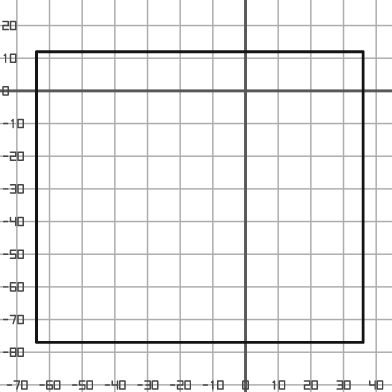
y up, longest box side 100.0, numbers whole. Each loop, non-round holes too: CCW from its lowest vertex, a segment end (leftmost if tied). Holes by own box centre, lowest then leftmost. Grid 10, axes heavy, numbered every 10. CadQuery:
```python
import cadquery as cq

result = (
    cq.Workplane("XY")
    .moveTo(-64.0, -77.0)
    .lineTo(36.0, -77.0)
    .lineTo(36.0, 12.0)
    .lineTo(-64.0, 12.0)
    .close()
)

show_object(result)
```